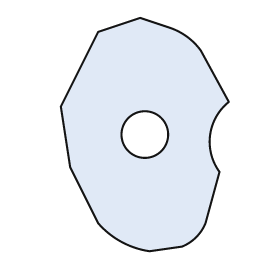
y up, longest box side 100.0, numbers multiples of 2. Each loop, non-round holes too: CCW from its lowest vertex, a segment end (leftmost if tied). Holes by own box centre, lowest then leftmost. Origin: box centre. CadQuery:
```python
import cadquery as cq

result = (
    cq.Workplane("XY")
    .moveTo(2.0, -50.0)
    .lineTo(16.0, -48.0)
    .threePointArc((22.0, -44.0), (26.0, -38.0))
    .lineTo(32.0, -16.0)
    .threePointArc((28.0, 0.0), (36.0, 14.0))
    .lineTo(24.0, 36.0)
    .threePointArc((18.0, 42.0), (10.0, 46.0))
    .lineTo(-2.0, 50.0)
    .lineTo(-20.0, 44.0)
    .lineTo(-36.0, 12.0)
    .lineTo(-32.0, -14.0)
    .lineTo(-20.0, -38.0)
    .threePointArc((-10.0, -46.0), (2.0, -50.0))
    .close()
    .moveTo(0.0, 0.0)
    .circle(10.0)
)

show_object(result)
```